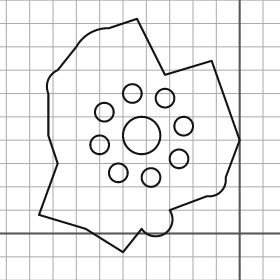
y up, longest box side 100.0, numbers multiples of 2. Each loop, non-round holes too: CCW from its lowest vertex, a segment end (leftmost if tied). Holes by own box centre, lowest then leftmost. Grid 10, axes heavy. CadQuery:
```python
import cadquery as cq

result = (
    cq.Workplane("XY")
    .moveTo(-50.0, -8.0)
    .lineTo(-42.0, 2.0)
    .threePointArc((-32.0, 0.0), (-30.0, 10.0))
    .lineTo(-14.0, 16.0)
    .threePointArc((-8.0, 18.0), (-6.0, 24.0))
    .lineTo(0.0, 40.0)
    .lineTo(-12.0, 74.0)
    .lineTo(-32.0, 68.0)
    .lineTo(-44.0, 92.0)
    .lineTo(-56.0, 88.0)
    .threePointArc((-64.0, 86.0), (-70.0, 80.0))
    .lineTo(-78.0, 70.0)
    .threePointArc((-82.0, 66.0), (-82.0, 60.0))
    .lineTo(-82.0, 42.0)
    .lineTo(-78.0, 30.0)
    .lineTo(-86.0, 8.0)
    .lineTo(-66.0, 2.0)
    .close()
    .moveTo(-38.0, 24.0)
    .circle(4.0)
    .moveTo(-52.0, 26.0)
    .circle(4.0)
    .moveTo(-26.0, 32.0)
    .circle(4.0)
    .moveTo(-60.0, 38.0)
    .circle(4.0)
    .moveTo(-42.0, 42.0)
    .circle(8.0)
    .moveTo(-24.0, 46.0)
    .circle(4.0)
    .moveTo(-58.0, 52.0)
    .circle(4.0)
    .moveTo(-32.0, 58.0)
    .circle(4.0)
    .moveTo(-46.0, 60.0)
    .circle(4.0)
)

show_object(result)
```